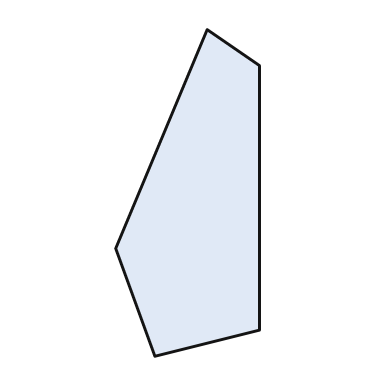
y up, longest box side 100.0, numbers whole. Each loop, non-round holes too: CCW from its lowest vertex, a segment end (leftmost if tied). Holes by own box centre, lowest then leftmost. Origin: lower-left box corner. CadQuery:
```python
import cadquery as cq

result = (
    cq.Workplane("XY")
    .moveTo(12.0, 0.0)
    .lineTo(44.0, 8.0)
    .lineTo(44.0, 89.0)
    .lineTo(28.0, 100.0)
    .lineTo(0.0, 33.0)
    .close()
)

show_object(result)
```